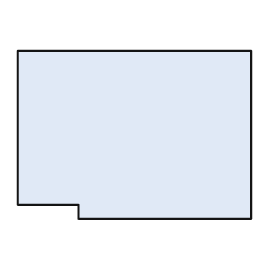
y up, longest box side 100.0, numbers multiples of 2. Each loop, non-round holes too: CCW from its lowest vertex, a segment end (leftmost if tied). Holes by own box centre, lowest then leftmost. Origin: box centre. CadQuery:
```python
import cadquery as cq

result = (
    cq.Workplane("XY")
    .moveTo(-24.0, -36.0)
    .lineTo(50.0, -36.0)
    .lineTo(50.0, 36.0)
    .lineTo(-50.0, 36.0)
    .lineTo(-50.0, -30.0)
    .lineTo(-24.0, -30.0)
    .close()
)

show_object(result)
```